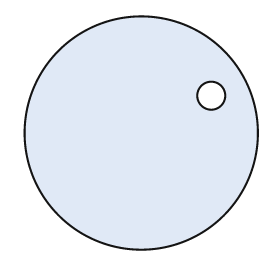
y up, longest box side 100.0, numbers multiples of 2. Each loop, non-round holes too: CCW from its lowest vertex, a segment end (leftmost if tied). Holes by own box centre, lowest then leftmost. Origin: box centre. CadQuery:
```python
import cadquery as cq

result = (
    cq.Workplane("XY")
    .moveTo(0.0, 0.0)
    .circle(50.0)
    .moveTo(30.0, 16.0)
    .circle(6.0)
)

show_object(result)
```